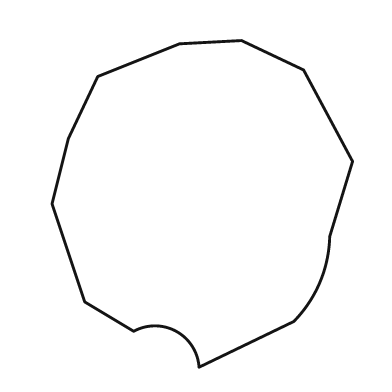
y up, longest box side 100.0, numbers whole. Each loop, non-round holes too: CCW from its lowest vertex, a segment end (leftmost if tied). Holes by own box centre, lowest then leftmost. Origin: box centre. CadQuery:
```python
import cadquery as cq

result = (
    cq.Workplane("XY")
    .moveTo(-1.0, -50.0)
    .lineTo(28.0, -36.0)
    .threePointArc((36.0, -24.0), (39.0, -10.0))
    .lineTo(46.0, 13.0)
    .lineTo(31.0, 41.0)
    .lineTo(12.0, 50.0)
    .lineTo(-7.0, 49.0)
    .lineTo(-32.0, 39.0)
    .lineTo(-41.0, 20.0)
    .lineTo(-46.0, 0.0)
    .lineTo(-36.0, -30.0)
    .lineTo(-21.0, -39.0)
    .threePointArc((-8.0, -39.0), (-1.0, -50.0))
    .close()
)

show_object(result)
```